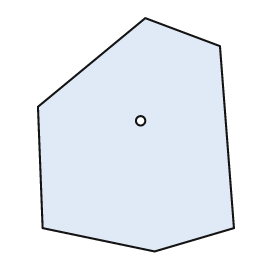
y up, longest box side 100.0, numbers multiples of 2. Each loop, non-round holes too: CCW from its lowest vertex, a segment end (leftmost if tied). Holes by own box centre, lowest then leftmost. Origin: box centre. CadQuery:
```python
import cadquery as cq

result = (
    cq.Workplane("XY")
    .moveTo(8.0, -50.0)
    .lineTo(42.0, -40.0)
    .lineTo(36.0, 38.0)
    .lineTo(4.0, 50.0)
    .lineTo(-42.0, 12.0)
    .lineTo(-40.0, -40.0)
    .close()
    .moveTo(2.0, 6.0)
    .circle(2.0)
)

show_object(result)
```